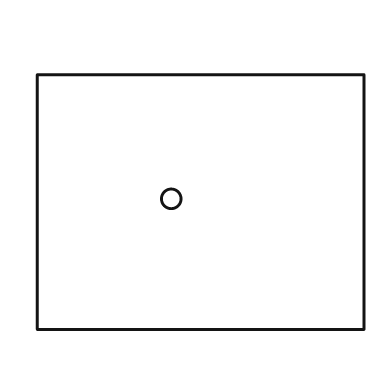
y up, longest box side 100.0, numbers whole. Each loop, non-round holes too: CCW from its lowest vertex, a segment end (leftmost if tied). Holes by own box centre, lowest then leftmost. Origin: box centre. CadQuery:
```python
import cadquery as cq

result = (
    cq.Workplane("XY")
    .moveTo(-50.0, -39.0)
    .lineTo(50.0, -39.0)
    .lineTo(50.0, 39.0)
    .lineTo(-50.0, 39.0)
    .close()
    .moveTo(-9.0, 1.0)
    .circle(3.0)
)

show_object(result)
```